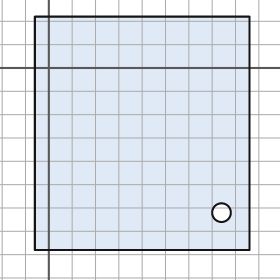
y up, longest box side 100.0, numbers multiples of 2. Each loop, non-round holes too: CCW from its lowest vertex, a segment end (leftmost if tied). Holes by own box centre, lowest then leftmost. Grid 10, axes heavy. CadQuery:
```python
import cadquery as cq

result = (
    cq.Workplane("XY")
    .moveTo(-6.0, -78.0)
    .lineTo(86.0, -78.0)
    .lineTo(86.0, 22.0)
    .lineTo(-6.0, 22.0)
    .close()
    .moveTo(74.0, -62.0)
    .circle(4.0)
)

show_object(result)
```